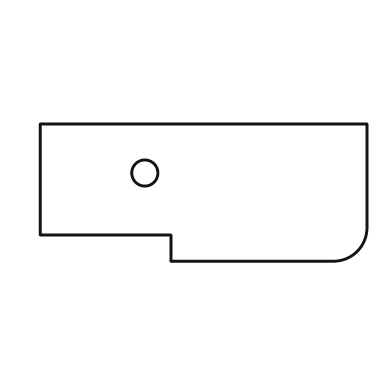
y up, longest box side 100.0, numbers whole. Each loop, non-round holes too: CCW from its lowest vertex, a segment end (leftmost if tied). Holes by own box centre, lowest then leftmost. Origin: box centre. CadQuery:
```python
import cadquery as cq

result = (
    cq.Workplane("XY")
    .moveTo(-10.0, -21.0)
    .lineTo(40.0, -21.0)
    .threePointArc((47.0, -18.0), (50.0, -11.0))
    .lineTo(50.0, 21.0)
    .lineTo(-50.0, 21.0)
    .lineTo(-50.0, -13.0)
    .lineTo(-10.0, -13.0)
    .close()
    .moveTo(-18.0, 6.0)
    .circle(4.0)
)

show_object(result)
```